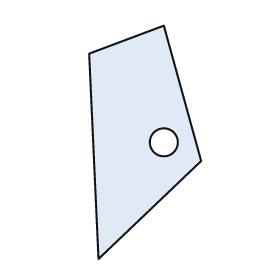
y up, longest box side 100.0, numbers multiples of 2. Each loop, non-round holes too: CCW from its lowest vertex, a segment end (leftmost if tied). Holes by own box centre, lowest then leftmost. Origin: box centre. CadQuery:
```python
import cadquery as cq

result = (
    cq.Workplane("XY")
    .moveTo(-20.0, -50.0)
    .lineTo(24.0, -8.0)
    .lineTo(8.0, 50.0)
    .lineTo(-24.0, 38.0)
    .close()
    .moveTo(8.0, 0.0)
    .circle(6.0)
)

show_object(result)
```